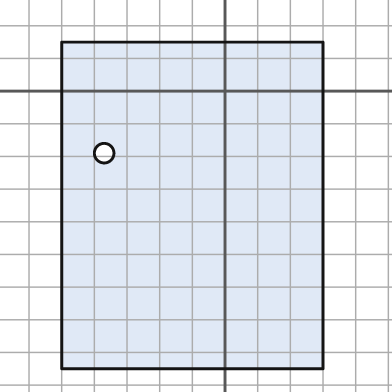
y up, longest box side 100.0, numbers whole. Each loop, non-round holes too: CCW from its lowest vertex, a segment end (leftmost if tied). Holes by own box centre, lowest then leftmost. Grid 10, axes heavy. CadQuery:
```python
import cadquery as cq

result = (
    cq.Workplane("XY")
    .moveTo(-50.0, -85.0)
    .lineTo(30.0, -85.0)
    .lineTo(30.0, 15.0)
    .lineTo(-50.0, 15.0)
    .close()
    .moveTo(-37.0, -19.0)
    .circle(3.0)
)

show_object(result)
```